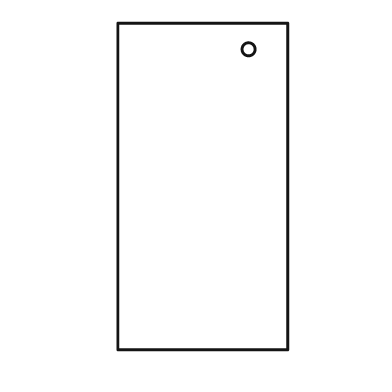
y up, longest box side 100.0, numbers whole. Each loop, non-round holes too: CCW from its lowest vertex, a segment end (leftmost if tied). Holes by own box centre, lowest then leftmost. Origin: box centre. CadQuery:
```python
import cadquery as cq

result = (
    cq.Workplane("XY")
    .moveTo(-26.0, -50.0)
    .lineTo(26.0, -50.0)
    .lineTo(26.0, 50.0)
    .lineTo(-26.0, 50.0)
    .close()
    .moveTo(14.0, 42.0)
    .circle(2.0)
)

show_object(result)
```